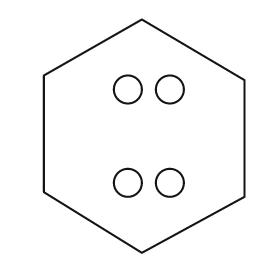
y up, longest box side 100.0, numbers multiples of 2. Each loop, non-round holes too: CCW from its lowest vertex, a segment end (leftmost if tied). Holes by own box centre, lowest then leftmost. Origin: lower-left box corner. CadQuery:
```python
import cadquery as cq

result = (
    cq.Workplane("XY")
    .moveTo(42.0, 0.0)
    .lineTo(86.0, 24.0)
    .lineTo(86.0, 74.0)
    .lineTo(42.0, 100.0)
    .lineTo(0.0, 76.0)
    .lineTo(0.0, 26.0)
    .close()
    .moveTo(36.0, 30.0)
    .circle(6.0)
    .moveTo(54.0, 30.0)
    .circle(6.0)
    .moveTo(36.0, 70.0)
    .circle(6.0)
    .moveTo(54.0, 70.0)
    .circle(6.0)
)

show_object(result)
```